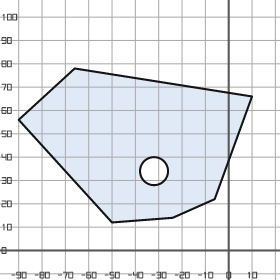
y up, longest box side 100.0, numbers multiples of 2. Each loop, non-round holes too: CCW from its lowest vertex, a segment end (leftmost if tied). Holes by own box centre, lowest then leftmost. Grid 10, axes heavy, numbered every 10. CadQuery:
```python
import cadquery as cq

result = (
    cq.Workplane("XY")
    .moveTo(-50.0, 12.0)
    .lineTo(-24.0, 14.0)
    .lineTo(-6.0, 22.0)
    .lineTo(10.0, 66.0)
    .lineTo(-66.0, 78.0)
    .lineTo(-90.0, 56.0)
    .close()
    .moveTo(-32.0, 34.0)
    .circle(6.0)
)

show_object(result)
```